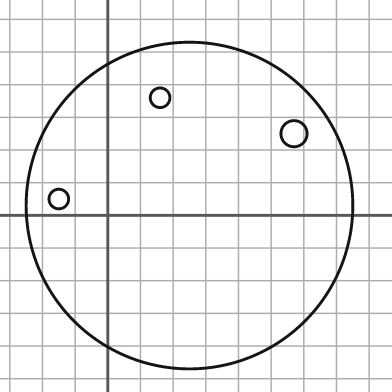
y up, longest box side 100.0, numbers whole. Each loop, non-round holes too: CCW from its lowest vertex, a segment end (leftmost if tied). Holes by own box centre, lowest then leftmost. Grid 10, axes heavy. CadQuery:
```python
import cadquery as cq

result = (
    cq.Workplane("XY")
    .moveTo(25.0, 3.0)
    .circle(50.0)
    .moveTo(-15.0, 5.0)
    .circle(3.0)
    .moveTo(57.0, 25.0)
    .circle(4.0)
    .moveTo(16.0, 36.0)
    .circle(3.0)
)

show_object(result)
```